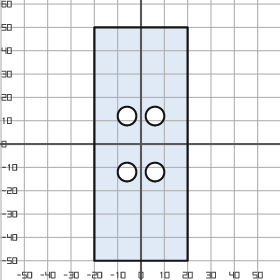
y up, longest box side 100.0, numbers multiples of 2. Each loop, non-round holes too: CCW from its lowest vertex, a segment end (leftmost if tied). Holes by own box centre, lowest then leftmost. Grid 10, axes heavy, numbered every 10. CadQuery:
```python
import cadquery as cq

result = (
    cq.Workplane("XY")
    .moveTo(-20.0, -50.0)
    .lineTo(20.0, -50.0)
    .lineTo(20.0, 50.0)
    .lineTo(-20.0, 50.0)
    .close()
    .moveTo(-6.0, -12.0)
    .circle(4.0)
    .moveTo(6.0, -12.0)
    .circle(4.0)
    .moveTo(-6.0, 12.0)
    .circle(4.0)
    .moveTo(6.0, 12.0)
    .circle(4.0)
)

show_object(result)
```